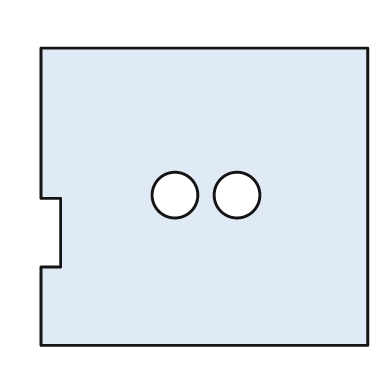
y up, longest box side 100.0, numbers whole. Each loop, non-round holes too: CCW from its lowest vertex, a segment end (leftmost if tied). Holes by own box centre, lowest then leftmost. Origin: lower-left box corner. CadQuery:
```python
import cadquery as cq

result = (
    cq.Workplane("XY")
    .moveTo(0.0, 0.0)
    .lineTo(100.0, 0.0)
    .lineTo(100.0, 91.0)
    .lineTo(0.0, 91.0)
    .lineTo(0.0, 45.0)
    .lineTo(6.0, 45.0)
    .lineTo(6.0, 24.0)
    .lineTo(0.0, 24.0)
    .close()
    .moveTo(41.0, 46.0)
    .circle(7.0)
    .moveTo(60.0, 46.0)
    .circle(7.0)
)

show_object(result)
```